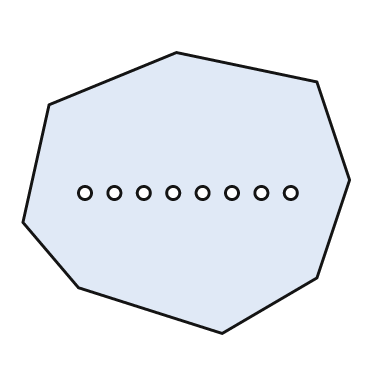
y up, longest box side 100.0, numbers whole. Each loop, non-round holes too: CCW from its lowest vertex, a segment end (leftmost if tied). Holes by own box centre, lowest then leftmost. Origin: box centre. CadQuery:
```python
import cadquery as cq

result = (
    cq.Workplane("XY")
    .moveTo(11.0, -43.0)
    .lineTo(40.0, -26.0)
    .lineTo(50.0, 4.0)
    .lineTo(40.0, 34.0)
    .lineTo(-3.0, 43.0)
    .lineTo(-42.0, 27.0)
    .lineTo(-50.0, -9.0)
    .lineTo(-33.0, -29.0)
    .close()
    .moveTo(-31.0, 0.0)
    .circle(2.0)
    .moveTo(-22.0, 0.0)
    .circle(2.0)
    .moveTo(-13.0, 0.0)
    .circle(2.0)
    .moveTo(-4.0, 0.0)
    .circle(2.0)
    .moveTo(5.0, 0.0)
    .circle(2.0)
    .moveTo(14.0, 0.0)
    .circle(2.0)
    .moveTo(23.0, 0.0)
    .circle(2.0)
    .moveTo(32.0, 0.0)
    .circle(2.0)
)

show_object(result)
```